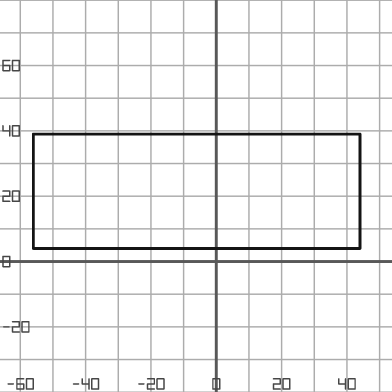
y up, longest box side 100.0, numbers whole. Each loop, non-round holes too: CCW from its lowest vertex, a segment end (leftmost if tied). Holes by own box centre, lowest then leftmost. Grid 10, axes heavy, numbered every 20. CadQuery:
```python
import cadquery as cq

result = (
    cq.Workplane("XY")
    .moveTo(-56.0, 4.0)
    .lineTo(44.0, 4.0)
    .lineTo(44.0, 39.0)
    .lineTo(-56.0, 39.0)
    .close()
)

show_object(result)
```